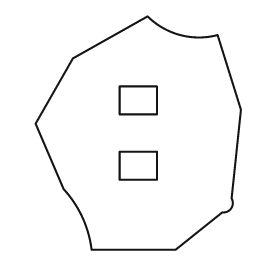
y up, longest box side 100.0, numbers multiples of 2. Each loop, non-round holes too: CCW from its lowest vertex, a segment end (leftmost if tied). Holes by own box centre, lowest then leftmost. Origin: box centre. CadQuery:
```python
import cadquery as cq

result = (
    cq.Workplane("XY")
    .moveTo(-20.0, -50.0)
    .lineTo(16.0, -50.0)
    .lineTo(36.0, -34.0)
    .threePointArc((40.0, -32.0), (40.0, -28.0))
    .lineTo(44.0, 10.0)
    .lineTo(34.0, 42.0)
    .threePointArc((18.0, 42.0), (4.0, 50.0))
    .lineTo(-28.0, 32.0)
    .lineTo(-44.0, 4.0)
    .lineTo(-32.0, -24.0)
    .threePointArc((-24.0, -36.0), (-20.0, -50.0))
    .close()
    .moveTo(-8.0, -20.0)
    .lineTo(8.0, -20.0)
    .lineTo(8.0, -8.0)
    .lineTo(-8.0, -8.0)
    .close()
    .moveTo(-8.0, 8.0)
    .lineTo(8.0, 8.0)
    .lineTo(8.0, 20.0)
    .lineTo(-8.0, 20.0)
    .close()
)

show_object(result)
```